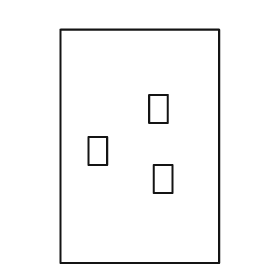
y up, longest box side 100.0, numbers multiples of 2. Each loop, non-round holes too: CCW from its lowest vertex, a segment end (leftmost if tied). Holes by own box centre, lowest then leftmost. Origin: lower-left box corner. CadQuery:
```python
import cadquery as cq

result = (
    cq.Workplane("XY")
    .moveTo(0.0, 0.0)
    .lineTo(68.0, 0.0)
    .lineTo(68.0, 100.0)
    .lineTo(0.0, 100.0)
    .close()
    .moveTo(40.0, 30.0)
    .lineTo(48.0, 30.0)
    .lineTo(48.0, 42.0)
    .lineTo(40.0, 42.0)
    .close()
    .moveTo(12.0, 42.0)
    .lineTo(20.0, 42.0)
    .lineTo(20.0, 54.0)
    .lineTo(12.0, 54.0)
    .close()
    .moveTo(38.0, 60.0)
    .lineTo(46.0, 60.0)
    .lineTo(46.0, 72.0)
    .lineTo(38.0, 72.0)
    .close()
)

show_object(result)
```